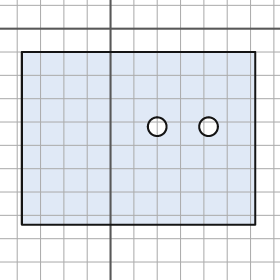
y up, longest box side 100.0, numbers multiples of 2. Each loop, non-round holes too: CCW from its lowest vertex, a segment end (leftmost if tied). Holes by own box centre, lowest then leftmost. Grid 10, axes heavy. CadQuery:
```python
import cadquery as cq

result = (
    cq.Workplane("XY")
    .moveTo(-38.0, -84.0)
    .lineTo(62.0, -84.0)
    .lineTo(62.0, -10.0)
    .lineTo(-38.0, -10.0)
    .close()
    .moveTo(20.0, -42.0)
    .circle(4.0)
    .moveTo(42.0, -42.0)
    .circle(4.0)
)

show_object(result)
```